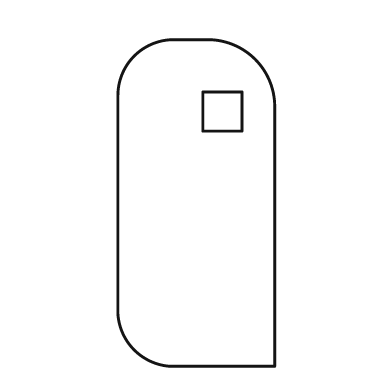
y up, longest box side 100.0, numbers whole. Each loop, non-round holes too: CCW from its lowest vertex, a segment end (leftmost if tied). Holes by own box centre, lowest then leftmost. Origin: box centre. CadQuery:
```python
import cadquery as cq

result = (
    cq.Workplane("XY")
    .moveTo(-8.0, -50.0)
    .lineTo(24.0, -50.0)
    .lineTo(24.0, 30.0)
    .threePointArc((18.0, 44.0), (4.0, 50.0))
    .lineTo(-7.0, 50.0)
    .threePointArc((-19.0, 45.0), (-24.0, 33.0))
    .lineTo(-24.0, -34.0)
    .threePointArc((-19.0, -45.0), (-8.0, -50.0))
    .close()
    .moveTo(2.0, 22.0)
    .lineTo(14.0, 22.0)
    .lineTo(14.0, 34.0)
    .lineTo(2.0, 34.0)
    .close()
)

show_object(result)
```